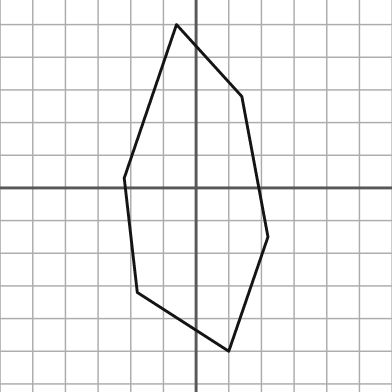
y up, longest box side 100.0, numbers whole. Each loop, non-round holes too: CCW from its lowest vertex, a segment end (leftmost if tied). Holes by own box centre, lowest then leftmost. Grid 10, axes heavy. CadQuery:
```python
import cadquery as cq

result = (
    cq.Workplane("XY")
    .moveTo(10.0, -50.0)
    .lineTo(22.0, -15.0)
    .lineTo(14.0, 28.0)
    .lineTo(-6.0, 50.0)
    .lineTo(-22.0, 3.0)
    .lineTo(-18.0, -32.0)
    .close()
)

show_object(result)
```